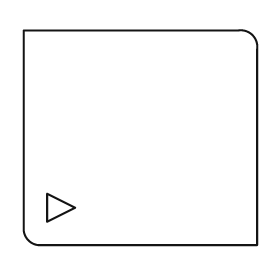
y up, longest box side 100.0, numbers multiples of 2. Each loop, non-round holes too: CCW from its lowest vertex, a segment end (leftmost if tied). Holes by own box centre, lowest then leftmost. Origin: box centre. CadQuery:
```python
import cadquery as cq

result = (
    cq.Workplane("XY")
    .moveTo(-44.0, -46.0)
    .lineTo(50.0, -46.0)
    .lineTo(50.0, 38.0)
    .threePointArc((48.0, 44.0), (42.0, 46.0))
    .lineTo(-50.0, 46.0)
    .lineTo(-50.0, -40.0)
    .threePointArc((-48.0, -44.0), (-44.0, -46.0))
    .close()
    .moveTo(-40.0, -36.0)
    .lineTo(-28.0, -30.0)
    .lineTo(-40.0, -24.0)
    .close()
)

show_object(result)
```